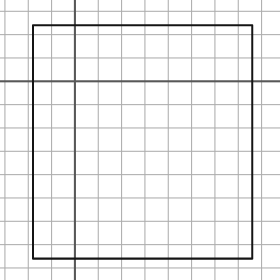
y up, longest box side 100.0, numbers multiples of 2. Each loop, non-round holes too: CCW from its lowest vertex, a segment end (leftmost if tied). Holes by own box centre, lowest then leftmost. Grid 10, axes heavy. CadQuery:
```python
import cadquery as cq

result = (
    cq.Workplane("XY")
    .moveTo(-18.0, -76.0)
    .lineTo(76.0, -76.0)
    .lineTo(76.0, 24.0)
    .lineTo(-18.0, 24.0)
    .close()
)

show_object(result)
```